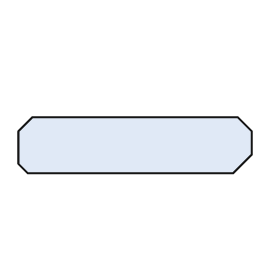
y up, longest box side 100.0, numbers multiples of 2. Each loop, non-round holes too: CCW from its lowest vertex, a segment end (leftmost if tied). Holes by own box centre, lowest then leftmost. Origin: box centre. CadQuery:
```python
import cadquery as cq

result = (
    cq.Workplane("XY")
    .moveTo(-46.0, -12.0)
    .lineTo(42.0, -12.0)
    .lineTo(50.0, -4.0)
    .lineTo(50.0, 6.0)
    .lineTo(44.0, 12.0)
    .lineTo(-44.0, 12.0)
    .lineTo(-50.0, 6.0)
    .lineTo(-50.0, -8.0)
    .close()
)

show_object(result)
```